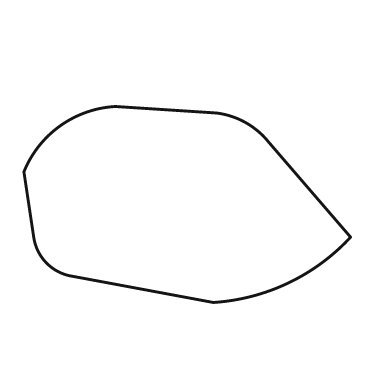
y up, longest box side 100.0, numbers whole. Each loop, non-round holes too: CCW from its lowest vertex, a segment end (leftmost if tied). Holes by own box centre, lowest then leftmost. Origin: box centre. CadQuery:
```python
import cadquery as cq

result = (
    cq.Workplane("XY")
    .moveTo(8.0, -30.0)
    .threePointArc((31.0, -24.0), (50.0, -10.0))
    .lineTo(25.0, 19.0)
    .threePointArc((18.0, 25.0), (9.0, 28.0))
    .lineTo(-22.0, 30.0)
    .threePointArc((-39.0, 24.0), (-50.0, 10.0))
    .lineTo(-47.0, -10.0)
    .threePointArc((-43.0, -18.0), (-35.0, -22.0))
    .close()
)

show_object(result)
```